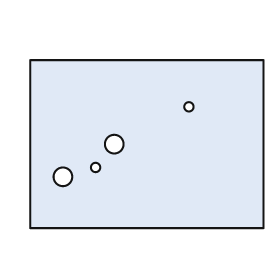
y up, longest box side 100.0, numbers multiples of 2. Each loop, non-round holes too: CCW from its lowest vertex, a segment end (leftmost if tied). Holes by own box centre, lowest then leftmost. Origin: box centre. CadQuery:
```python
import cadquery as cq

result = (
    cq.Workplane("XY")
    .moveTo(-50.0, -36.0)
    .lineTo(50.0, -36.0)
    .lineTo(50.0, 36.0)
    .lineTo(-50.0, 36.0)
    .close()
    .moveTo(-36.0, -14.0)
    .circle(4.0)
    .moveTo(-22.0, -10.0)
    .circle(2.0)
    .moveTo(-14.0, 0.0)
    .circle(4.0)
    .moveTo(18.0, 16.0)
    .circle(2.0)
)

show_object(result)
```